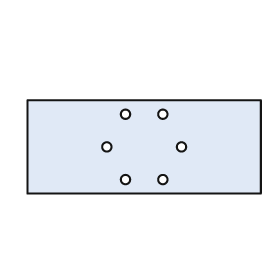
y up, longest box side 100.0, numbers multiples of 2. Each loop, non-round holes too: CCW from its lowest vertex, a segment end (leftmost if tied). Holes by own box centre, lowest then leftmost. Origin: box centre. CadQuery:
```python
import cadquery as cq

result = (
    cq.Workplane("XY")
    .moveTo(-50.0, -20.0)
    .lineTo(50.0, -20.0)
    .lineTo(50.0, 20.0)
    .lineTo(-50.0, 20.0)
    .close()
    .moveTo(-8.0, -14.0)
    .circle(2.0)
    .moveTo(8.0, -14.0)
    .circle(2.0)
    .moveTo(-16.0, 0.0)
    .circle(2.0)
    .moveTo(16.0, 0.0)
    .circle(2.0)
    .moveTo(-8.0, 14.0)
    .circle(2.0)
    .moveTo(8.0, 14.0)
    .circle(2.0)
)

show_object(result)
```